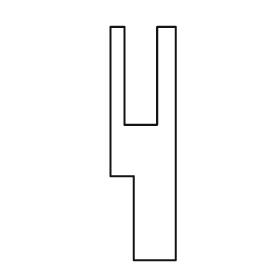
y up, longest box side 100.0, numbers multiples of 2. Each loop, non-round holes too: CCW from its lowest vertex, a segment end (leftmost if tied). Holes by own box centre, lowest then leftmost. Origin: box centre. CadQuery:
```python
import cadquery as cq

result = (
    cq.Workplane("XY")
    .moveTo(-4.0, -50.0)
    .lineTo(14.0, -50.0)
    .lineTo(14.0, 50.0)
    .lineTo(6.0, 50.0)
    .lineTo(6.0, 8.0)
    .lineTo(-8.0, 8.0)
    .lineTo(-8.0, 50.0)
    .lineTo(-14.0, 50.0)
    .lineTo(-14.0, -14.0)
    .lineTo(-4.0, -14.0)
    .close()
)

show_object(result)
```